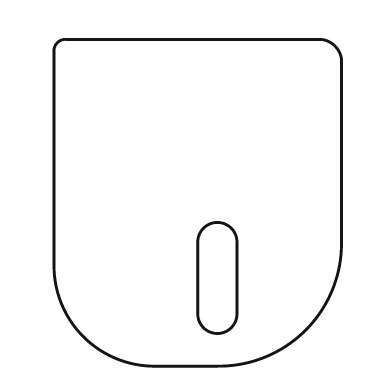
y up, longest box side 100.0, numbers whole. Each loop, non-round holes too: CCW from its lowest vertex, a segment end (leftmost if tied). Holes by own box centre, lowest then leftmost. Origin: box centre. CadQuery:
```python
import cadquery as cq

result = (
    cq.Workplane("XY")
    .moveTo(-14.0, -50.0)
    .lineTo(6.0, -50.0)
    .threePointArc((33.0, -39.0), (44.0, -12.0))
    .lineTo(44.0, 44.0)
    .threePointArc((42.0, 48.0), (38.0, 50.0))
    .lineTo(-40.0, 50.0)
    .threePointArc((-43.0, 49.0), (-44.0, 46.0))
    .lineTo(-44.0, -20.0)
    .threePointArc((-35.0, -41.0), (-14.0, -50.0))
    .close()
    .moveTo(0.0, -34.0)
    .threePointArc((6.0, -40.0), (12.0, -34.0))
    .lineTo(12.0, -12.0)
    .threePointArc((6.0, -6.0), (0.0, -12.0))
    .close()
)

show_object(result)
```